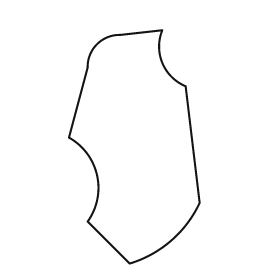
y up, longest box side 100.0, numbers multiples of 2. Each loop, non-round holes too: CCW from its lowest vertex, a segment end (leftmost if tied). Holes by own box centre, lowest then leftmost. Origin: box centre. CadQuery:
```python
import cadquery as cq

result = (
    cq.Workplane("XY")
    .moveTo(-2.0, -50.0)
    .threePointArc((16.0, -40.0), (28.0, -24.0))
    .lineTo(22.0, 26.0)
    .threePointArc((12.0, 36.0), (12.0, 50.0))
    .lineTo(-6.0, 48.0)
    .threePointArc((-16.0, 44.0), (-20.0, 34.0))
    .lineTo(-28.0, 4.0)
    .threePointArc((-16.0, -12.0), (-20.0, -32.0))
    .close()
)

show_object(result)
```